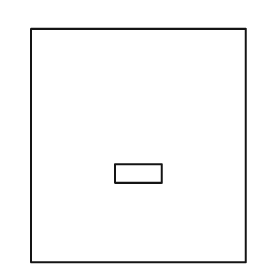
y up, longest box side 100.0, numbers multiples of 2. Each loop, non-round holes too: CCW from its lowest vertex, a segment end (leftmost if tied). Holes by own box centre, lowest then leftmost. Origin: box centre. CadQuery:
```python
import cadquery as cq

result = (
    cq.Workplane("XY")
    .moveTo(-46.0, -50.0)
    .lineTo(46.0, -50.0)
    .lineTo(46.0, 50.0)
    .lineTo(-46.0, 50.0)
    .close()
    .moveTo(-10.0, -16.0)
    .lineTo(10.0, -16.0)
    .lineTo(10.0, -8.0)
    .lineTo(-10.0, -8.0)
    .close()
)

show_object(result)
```